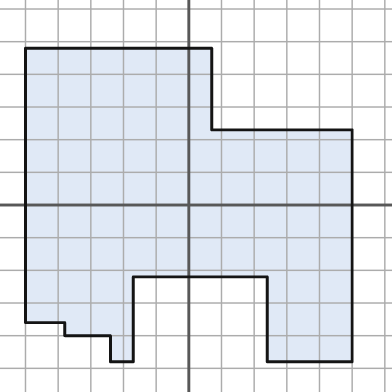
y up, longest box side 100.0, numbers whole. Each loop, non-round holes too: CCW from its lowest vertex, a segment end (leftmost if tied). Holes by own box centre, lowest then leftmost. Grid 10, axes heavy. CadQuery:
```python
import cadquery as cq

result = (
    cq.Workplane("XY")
    .moveTo(-24.0, -48.0)
    .lineTo(-17.0, -48.0)
    .lineTo(-17.0, -22.0)
    .lineTo(24.0, -22.0)
    .lineTo(24.0, -48.0)
    .lineTo(50.0, -48.0)
    .lineTo(50.0, 23.0)
    .lineTo(7.0, 23.0)
    .lineTo(7.0, 48.0)
    .lineTo(-50.0, 48.0)
    .lineTo(-50.0, -36.0)
    .lineTo(-38.0, -36.0)
    .lineTo(-38.0, -40.0)
    .lineTo(-24.0, -40.0)
    .close()
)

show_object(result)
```